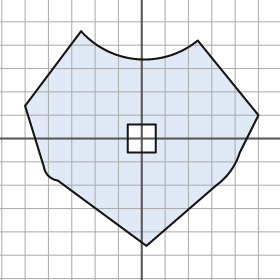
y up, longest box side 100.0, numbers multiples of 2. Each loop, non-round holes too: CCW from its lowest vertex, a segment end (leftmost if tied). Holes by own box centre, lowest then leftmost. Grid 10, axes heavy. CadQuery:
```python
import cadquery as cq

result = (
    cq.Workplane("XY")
    .moveTo(2.0, -46.0)
    .lineTo(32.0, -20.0)
    .threePointArc((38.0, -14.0), (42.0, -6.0))
    .lineTo(50.0, 10.0)
    .lineTo(24.0, 42.0)
    .threePointArc((-2.0, 34.0), (-26.0, 46.0))
    .lineTo(-50.0, 14.0)
    .lineTo(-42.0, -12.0)
    .threePointArc((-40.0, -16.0), (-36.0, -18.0))
    .close()
    .moveTo(-6.0, -6.0)
    .lineTo(6.0, -6.0)
    .lineTo(6.0, 6.0)
    .lineTo(-6.0, 6.0)
    .close()
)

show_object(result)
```